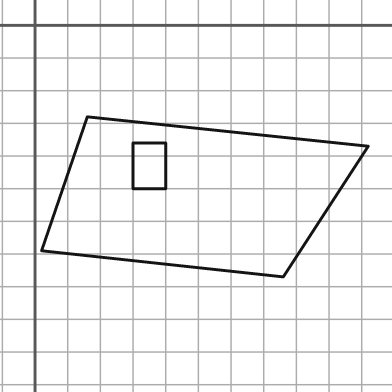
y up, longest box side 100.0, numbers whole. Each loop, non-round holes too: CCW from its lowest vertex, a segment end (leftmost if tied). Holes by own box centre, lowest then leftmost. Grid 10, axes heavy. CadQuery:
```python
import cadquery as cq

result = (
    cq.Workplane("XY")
    .moveTo(76.0, -77.0)
    .lineTo(102.0, -37.0)
    .lineTo(16.0, -28.0)
    .lineTo(2.0, -69.0)
    .close()
    .moveTo(30.0, -50.0)
    .lineTo(40.0, -50.0)
    .lineTo(40.0, -36.0)
    .lineTo(30.0, -36.0)
    .close()
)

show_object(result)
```